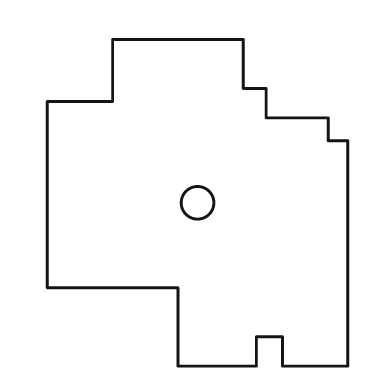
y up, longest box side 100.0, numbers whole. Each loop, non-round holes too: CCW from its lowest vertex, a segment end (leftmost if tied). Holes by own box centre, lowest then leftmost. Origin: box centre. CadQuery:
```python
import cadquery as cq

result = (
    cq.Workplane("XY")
    .moveTo(-6.0, -50.0)
    .lineTo(18.0, -50.0)
    .lineTo(18.0, -41.0)
    .lineTo(26.0, -41.0)
    .lineTo(26.0, -50.0)
    .lineTo(46.0, -50.0)
    .lineTo(46.0, 19.0)
    .lineTo(40.0, 19.0)
    .lineTo(40.0, 26.0)
    .lineTo(21.0, 26.0)
    .lineTo(21.0, 35.0)
    .lineTo(14.0, 35.0)
    .lineTo(14.0, 50.0)
    .lineTo(-26.0, 50.0)
    .lineTo(-26.0, 31.0)
    .lineTo(-46.0, 31.0)
    .lineTo(-46.0, -26.0)
    .lineTo(-6.0, -26.0)
    .close()
    .moveTo(0.0, 0.0)
    .circle(5.0)
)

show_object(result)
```